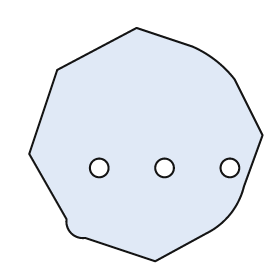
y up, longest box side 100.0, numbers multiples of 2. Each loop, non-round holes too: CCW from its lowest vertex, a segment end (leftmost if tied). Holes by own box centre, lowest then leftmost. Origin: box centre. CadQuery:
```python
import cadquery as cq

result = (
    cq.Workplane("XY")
    .moveTo(4.0, -50.0)
    .lineTo(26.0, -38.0)
    .threePointArc((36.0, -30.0), (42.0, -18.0))
    .lineTo(50.0, 4.0)
    .lineTo(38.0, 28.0)
    .threePointArc((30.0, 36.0), (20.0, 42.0))
    .lineTo(-4.0, 50.0)
    .lineTo(-38.0, 32.0)
    .lineTo(-50.0, -4.0)
    .lineTo(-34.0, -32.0)
    .threePointArc((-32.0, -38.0), (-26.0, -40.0))
    .close()
    .moveTo(-20.0, -10.0)
    .circle(4.0)
    .moveTo(8.0, -10.0)
    .circle(4.0)
    .moveTo(36.0, -10.0)
    .circle(4.0)
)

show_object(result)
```